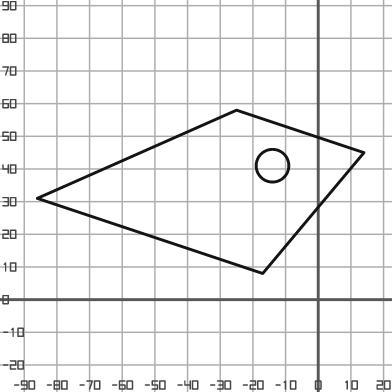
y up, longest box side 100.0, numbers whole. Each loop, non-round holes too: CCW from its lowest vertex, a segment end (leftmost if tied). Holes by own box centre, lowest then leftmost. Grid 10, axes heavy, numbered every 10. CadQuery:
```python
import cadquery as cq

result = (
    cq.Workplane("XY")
    .moveTo(-17.0, 8.0)
    .lineTo(14.0, 45.0)
    .lineTo(-25.0, 58.0)
    .lineTo(-86.0, 31.0)
    .close()
    .moveTo(-14.0, 41.0)
    .circle(5.0)
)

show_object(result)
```